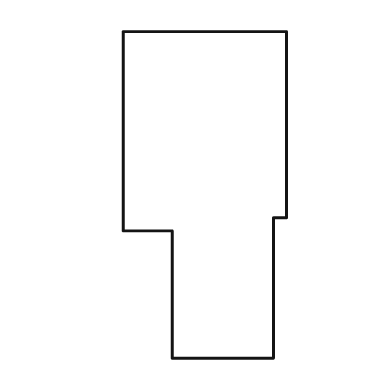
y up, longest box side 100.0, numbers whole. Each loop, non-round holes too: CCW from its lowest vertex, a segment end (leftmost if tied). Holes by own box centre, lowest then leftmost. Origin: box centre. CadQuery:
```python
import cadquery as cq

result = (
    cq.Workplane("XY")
    .moveTo(-10.0, -50.0)
    .lineTo(21.0, -50.0)
    .lineTo(21.0, -7.0)
    .lineTo(25.0, -7.0)
    .lineTo(25.0, 50.0)
    .lineTo(-25.0, 50.0)
    .lineTo(-25.0, -11.0)
    .lineTo(-10.0, -11.0)
    .close()
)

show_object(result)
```